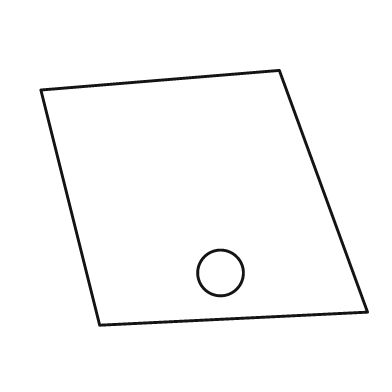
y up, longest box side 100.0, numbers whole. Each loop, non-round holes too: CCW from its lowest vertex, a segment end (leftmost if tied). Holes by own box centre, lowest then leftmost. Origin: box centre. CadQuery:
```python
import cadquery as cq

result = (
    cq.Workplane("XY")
    .moveTo(-32.0, -39.0)
    .lineTo(50.0, -35.0)
    .lineTo(23.0, 39.0)
    .lineTo(-50.0, 33.0)
    .close()
    .moveTo(5.0, -23.0)
    .circle(7.0)
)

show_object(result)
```